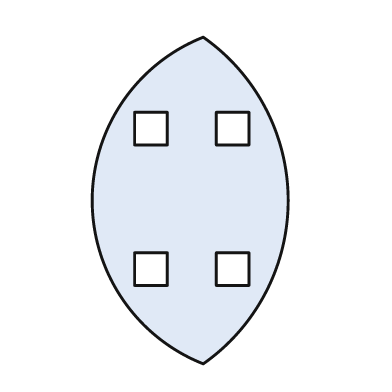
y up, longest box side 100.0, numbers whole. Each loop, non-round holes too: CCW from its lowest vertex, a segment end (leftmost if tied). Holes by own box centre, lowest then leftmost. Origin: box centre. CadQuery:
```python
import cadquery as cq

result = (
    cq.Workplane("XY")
    .moveTo(4.0, -50.0)
    .threePointArc((30.0, 0.0), (4.0, 50.0))
    .threePointArc((-30.0, 0.0), (4.0, -50.0))
    .close()
    .moveTo(-17.0, -26.0)
    .lineTo(-7.0, -26.0)
    .lineTo(-7.0, -16.0)
    .lineTo(-17.0, -16.0)
    .close()
    .moveTo(8.0, -26.0)
    .lineTo(18.0, -26.0)
    .lineTo(18.0, -16.0)
    .lineTo(8.0, -16.0)
    .close()
    .moveTo(-17.0, 17.0)
    .lineTo(-7.0, 17.0)
    .lineTo(-7.0, 27.0)
    .lineTo(-17.0, 27.0)
    .close()
    .moveTo(8.0, 17.0)
    .lineTo(18.0, 17.0)
    .lineTo(18.0, 27.0)
    .lineTo(8.0, 27.0)
    .close()
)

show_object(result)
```